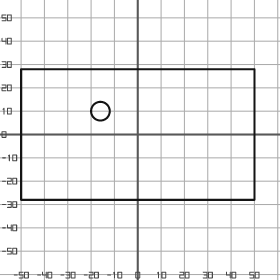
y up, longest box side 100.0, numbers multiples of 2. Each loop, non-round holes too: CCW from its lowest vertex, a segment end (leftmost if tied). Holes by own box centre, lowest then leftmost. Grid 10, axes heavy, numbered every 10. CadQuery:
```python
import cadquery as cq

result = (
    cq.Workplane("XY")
    .moveTo(-50.0, -28.0)
    .lineTo(50.0, -28.0)
    .lineTo(50.0, 28.0)
    .lineTo(-50.0, 28.0)
    .close()
    .moveTo(-16.0, 10.0)
    .circle(4.0)
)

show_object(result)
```